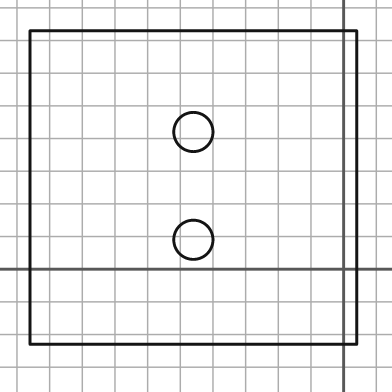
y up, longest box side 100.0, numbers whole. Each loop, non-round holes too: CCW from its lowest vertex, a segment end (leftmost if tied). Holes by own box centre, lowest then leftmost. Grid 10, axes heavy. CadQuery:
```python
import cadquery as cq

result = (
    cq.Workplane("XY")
    .moveTo(-96.0, -23.0)
    .lineTo(4.0, -23.0)
    .lineTo(4.0, 73.0)
    .lineTo(-96.0, 73.0)
    .close()
    .moveTo(-46.0, 9.0)
    .circle(6.0)
    .moveTo(-46.0, 42.0)
    .circle(6.0)
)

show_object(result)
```